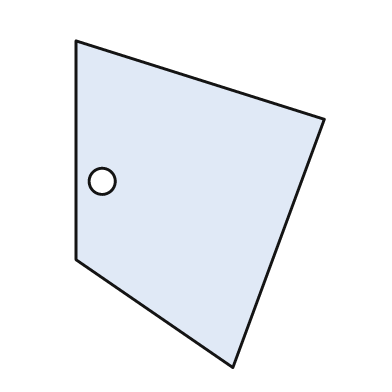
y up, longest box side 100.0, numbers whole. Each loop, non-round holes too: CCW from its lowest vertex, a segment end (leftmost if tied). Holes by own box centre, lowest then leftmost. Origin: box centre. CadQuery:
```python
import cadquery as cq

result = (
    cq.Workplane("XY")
    .moveTo(10.0, -50.0)
    .lineTo(38.0, 26.0)
    .lineTo(-38.0, 50.0)
    .lineTo(-38.0, -17.0)
    .close()
    .moveTo(-30.0, 7.0)
    .circle(4.0)
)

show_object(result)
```